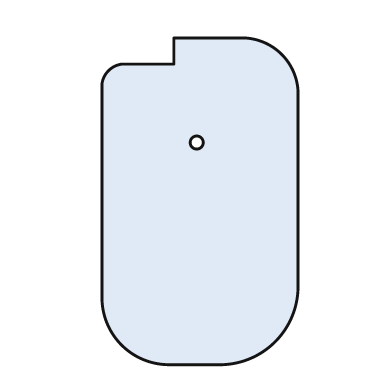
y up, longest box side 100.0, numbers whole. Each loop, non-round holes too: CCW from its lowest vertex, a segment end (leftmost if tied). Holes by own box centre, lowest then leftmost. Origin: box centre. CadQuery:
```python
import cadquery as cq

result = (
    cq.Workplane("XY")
    .moveTo(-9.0, -50.0)
    .lineTo(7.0, -50.0)
    .threePointArc((23.0, -43.0), (30.0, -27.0))
    .lineTo(30.0, 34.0)
    .threePointArc((25.0, 45.0), (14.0, 50.0))
    .lineTo(-8.0, 50.0)
    .lineTo(-8.0, 42.0)
    .lineTo(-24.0, 42.0)
    .threePointArc((-28.0, 40.0), (-30.0, 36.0))
    .lineTo(-30.0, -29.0)
    .threePointArc((-24.0, -44.0), (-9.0, -50.0))
    .close()
    .moveTo(-1.0, 18.0)
    .circle(2.0)
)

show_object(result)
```